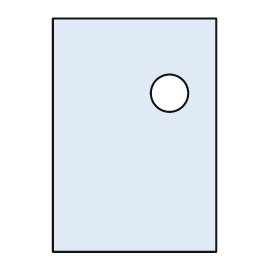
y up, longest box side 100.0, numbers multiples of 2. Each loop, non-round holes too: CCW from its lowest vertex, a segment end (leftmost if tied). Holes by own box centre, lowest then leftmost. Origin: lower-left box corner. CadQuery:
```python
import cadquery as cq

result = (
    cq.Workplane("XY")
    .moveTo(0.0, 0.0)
    .lineTo(70.0, 0.0)
    .lineTo(70.0, 100.0)
    .lineTo(0.0, 100.0)
    .close()
    .moveTo(50.0, 68.0)
    .circle(8.0)
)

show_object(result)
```